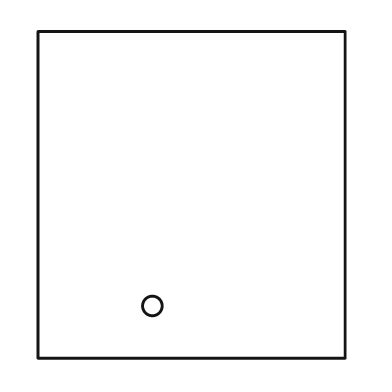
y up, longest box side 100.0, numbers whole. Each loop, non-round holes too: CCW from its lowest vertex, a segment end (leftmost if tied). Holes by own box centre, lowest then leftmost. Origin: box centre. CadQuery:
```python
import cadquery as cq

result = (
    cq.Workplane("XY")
    .moveTo(-47.0, -50.0)
    .lineTo(47.0, -50.0)
    .lineTo(47.0, 50.0)
    .lineTo(-47.0, 50.0)
    .close()
    .moveTo(-12.0, -34.0)
    .circle(3.0)
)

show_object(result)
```